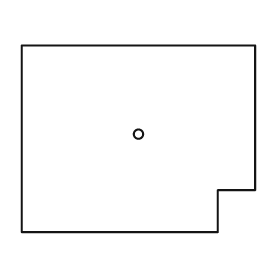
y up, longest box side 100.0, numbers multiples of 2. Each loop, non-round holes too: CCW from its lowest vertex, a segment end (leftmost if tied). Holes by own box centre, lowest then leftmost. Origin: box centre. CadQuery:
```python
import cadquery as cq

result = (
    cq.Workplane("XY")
    .moveTo(-50.0, -40.0)
    .lineTo(34.0, -40.0)
    .lineTo(34.0, -22.0)
    .lineTo(50.0, -22.0)
    .lineTo(50.0, 40.0)
    .lineTo(-50.0, 40.0)
    .close()
    .moveTo(0.0, 2.0)
    .circle(2.0)
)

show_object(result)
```